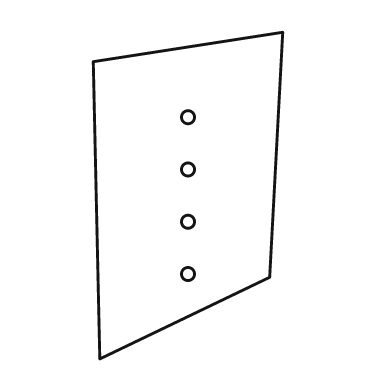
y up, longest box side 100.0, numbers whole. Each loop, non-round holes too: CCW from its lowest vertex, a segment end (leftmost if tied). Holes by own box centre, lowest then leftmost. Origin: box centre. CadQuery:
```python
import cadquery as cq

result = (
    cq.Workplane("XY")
    .moveTo(-27.0, -50.0)
    .lineTo(25.0, -25.0)
    .lineTo(29.0, 50.0)
    .lineTo(-29.0, 41.0)
    .close()
    .moveTo(0.0, -24.0)
    .circle(2.0)
    .moveTo(0.0, -8.0)
    .circle(2.0)
    .moveTo(0.0, 8.0)
    .circle(2.0)
    .moveTo(0.0, 24.0)
    .circle(2.0)
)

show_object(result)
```